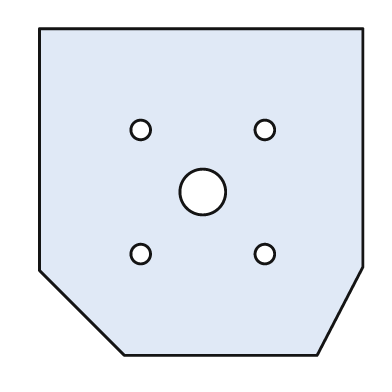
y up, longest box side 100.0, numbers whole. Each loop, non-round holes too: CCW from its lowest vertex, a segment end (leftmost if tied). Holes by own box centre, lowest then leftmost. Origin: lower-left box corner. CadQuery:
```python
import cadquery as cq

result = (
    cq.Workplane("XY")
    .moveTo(26.0, 0.0)
    .lineTo(85.0, 0.0)
    .lineTo(99.0, 27.0)
    .lineTo(99.0, 100.0)
    .lineTo(0.0, 100.0)
    .lineTo(0.0, 26.0)
    .close()
    .moveTo(31.0, 31.0)
    .circle(3.0)
    .moveTo(69.0, 31.0)
    .circle(3.0)
    .moveTo(50.0, 50.0)
    .circle(7.0)
    .moveTo(31.0, 69.0)
    .circle(3.0)
    .moveTo(69.0, 69.0)
    .circle(3.0)
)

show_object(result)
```